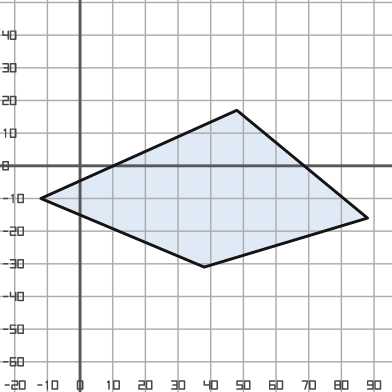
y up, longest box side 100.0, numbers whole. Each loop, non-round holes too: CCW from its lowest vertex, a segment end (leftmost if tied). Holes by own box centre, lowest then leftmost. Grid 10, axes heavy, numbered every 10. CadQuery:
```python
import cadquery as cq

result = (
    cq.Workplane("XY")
    .moveTo(38.0, -31.0)
    .lineTo(88.0, -16.0)
    .lineTo(48.0, 17.0)
    .lineTo(-12.0, -10.0)
    .close()
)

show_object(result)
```